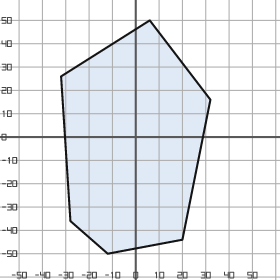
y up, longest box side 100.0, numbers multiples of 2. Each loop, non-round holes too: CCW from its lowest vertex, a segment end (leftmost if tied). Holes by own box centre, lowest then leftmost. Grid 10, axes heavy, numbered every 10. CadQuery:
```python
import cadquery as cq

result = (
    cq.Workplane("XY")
    .moveTo(-12.0, -50.0)
    .lineTo(20.0, -44.0)
    .lineTo(32.0, 16.0)
    .lineTo(6.0, 50.0)
    .lineTo(-32.0, 26.0)
    .lineTo(-28.0, -36.0)
    .close()
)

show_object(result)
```